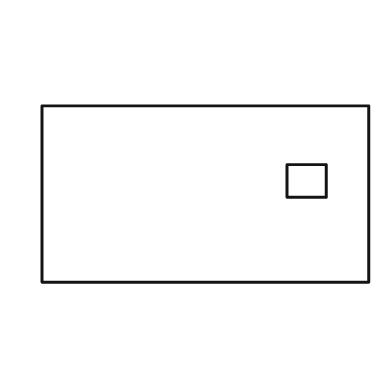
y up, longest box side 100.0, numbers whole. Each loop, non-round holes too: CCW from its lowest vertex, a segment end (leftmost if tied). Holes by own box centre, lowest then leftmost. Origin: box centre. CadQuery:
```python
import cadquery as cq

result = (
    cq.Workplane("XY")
    .moveTo(-50.0, -27.0)
    .lineTo(50.0, -27.0)
    .lineTo(50.0, 27.0)
    .lineTo(-50.0, 27.0)
    .close()
    .moveTo(25.0, -1.0)
    .lineTo(37.0, -1.0)
    .lineTo(37.0, 9.0)
    .lineTo(25.0, 9.0)
    .close()
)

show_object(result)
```